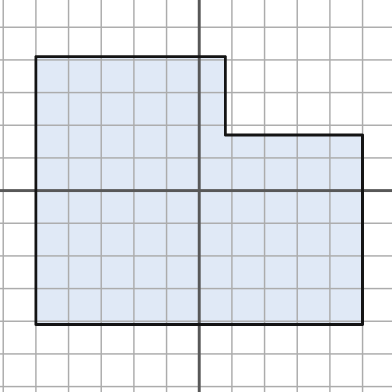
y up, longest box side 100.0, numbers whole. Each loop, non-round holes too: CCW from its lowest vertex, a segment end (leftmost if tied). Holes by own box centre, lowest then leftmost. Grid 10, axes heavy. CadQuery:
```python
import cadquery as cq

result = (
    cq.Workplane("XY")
    .moveTo(-50.0, -41.0)
    .lineTo(50.0, -41.0)
    .lineTo(50.0, 17.0)
    .lineTo(8.0, 17.0)
    .lineTo(8.0, 41.0)
    .lineTo(-50.0, 41.0)
    .close()
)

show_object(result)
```